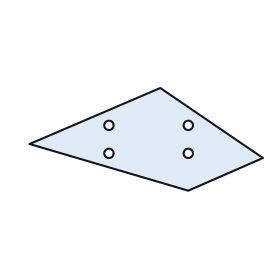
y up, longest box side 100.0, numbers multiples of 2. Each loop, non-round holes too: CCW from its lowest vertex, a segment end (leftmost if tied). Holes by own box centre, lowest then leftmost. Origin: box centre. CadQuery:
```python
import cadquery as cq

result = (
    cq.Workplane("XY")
    .moveTo(18.0, -22.0)
    .lineTo(50.0, -8.0)
    .lineTo(6.0, 22.0)
    .lineTo(-50.0, -2.0)
    .close()
    .moveTo(-16.0, -6.0)
    .circle(2.0)
    .moveTo(18.0, -6.0)
    .circle(2.0)
    .moveTo(-16.0, 6.0)
    .circle(2.0)
    .moveTo(18.0, 6.0)
    .circle(2.0)
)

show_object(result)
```